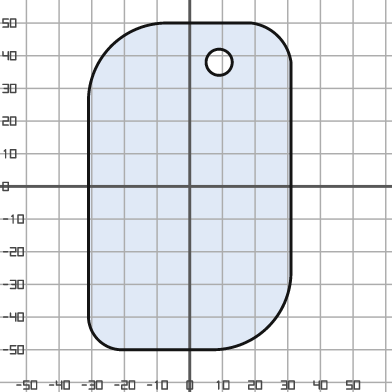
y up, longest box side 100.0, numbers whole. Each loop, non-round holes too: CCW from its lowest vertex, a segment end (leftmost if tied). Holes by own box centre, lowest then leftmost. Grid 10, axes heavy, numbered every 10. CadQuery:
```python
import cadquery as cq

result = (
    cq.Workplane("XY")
    .moveTo(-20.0, -50.0)
    .lineTo(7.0, -50.0)
    .threePointArc((24.0, -43.0), (31.0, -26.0))
    .lineTo(31.0, 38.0)
    .threePointArc((27.0, 46.0), (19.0, 50.0))
    .lineTo(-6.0, 50.0)
    .threePointArc((-24.0, 43.0), (-31.0, 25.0))
    .lineTo(-31.0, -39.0)
    .threePointArc((-28.0, -47.0), (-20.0, -50.0))
    .close()
    .moveTo(9.0, 38.0)
    .circle(4.0)
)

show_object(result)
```